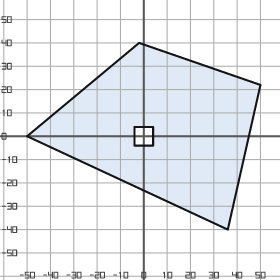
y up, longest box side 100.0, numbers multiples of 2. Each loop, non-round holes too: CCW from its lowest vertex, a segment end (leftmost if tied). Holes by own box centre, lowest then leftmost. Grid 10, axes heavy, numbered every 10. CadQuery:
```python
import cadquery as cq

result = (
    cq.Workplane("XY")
    .moveTo(36.0, -40.0)
    .lineTo(50.0, 22.0)
    .lineTo(-2.0, 40.0)
    .lineTo(-50.0, 0.0)
    .close()
    .moveTo(-4.0, -4.0)
    .lineTo(4.0, -4.0)
    .lineTo(4.0, 4.0)
    .lineTo(-4.0, 4.0)
    .close()
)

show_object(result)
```